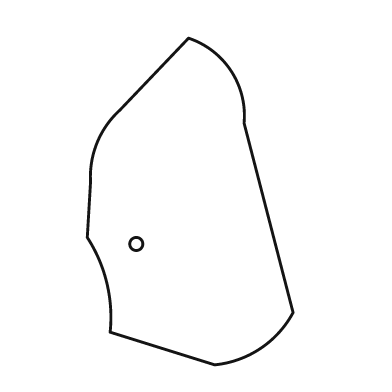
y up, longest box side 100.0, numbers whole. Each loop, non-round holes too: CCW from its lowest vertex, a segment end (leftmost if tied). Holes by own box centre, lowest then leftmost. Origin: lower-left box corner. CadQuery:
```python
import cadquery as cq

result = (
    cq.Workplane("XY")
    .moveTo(39.0, 0.0)
    .threePointArc((53.0, 5.0), (63.0, 16.0))
    .lineTo(48.0, 74.0)
    .threePointArc((44.0, 90.0), (31.0, 100.0))
    .lineTo(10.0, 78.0)
    .threePointArc((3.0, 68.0), (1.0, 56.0))
    .lineTo(0.0, 39.0)
    .threePointArc((6.0, 25.0), (7.0, 10.0))
    .close()
    .moveTo(15.0, 37.0)
    .circle(2.0)
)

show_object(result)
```